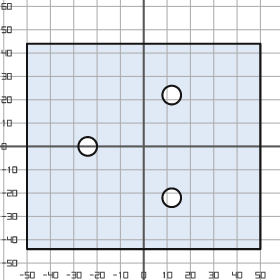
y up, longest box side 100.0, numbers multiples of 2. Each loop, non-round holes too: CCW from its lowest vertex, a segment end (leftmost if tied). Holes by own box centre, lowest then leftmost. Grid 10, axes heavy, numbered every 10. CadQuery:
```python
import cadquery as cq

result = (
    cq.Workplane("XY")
    .moveTo(-50.0, -44.0)
    .lineTo(50.0, -44.0)
    .lineTo(50.0, 44.0)
    .lineTo(-50.0, 44.0)
    .close()
    .moveTo(12.0, -22.0)
    .circle(4.0)
    .moveTo(-24.0, 0.0)
    .circle(4.0)
    .moveTo(12.0, 22.0)
    .circle(4.0)
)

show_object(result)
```